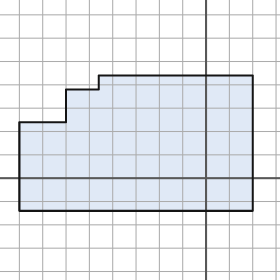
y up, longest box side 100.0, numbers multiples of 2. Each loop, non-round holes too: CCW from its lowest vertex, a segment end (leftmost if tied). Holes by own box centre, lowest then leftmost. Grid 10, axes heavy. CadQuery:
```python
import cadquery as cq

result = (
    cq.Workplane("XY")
    .moveTo(-80.0, -14.0)
    .lineTo(20.0, -14.0)
    .lineTo(20.0, 44.0)
    .lineTo(-46.0, 44.0)
    .lineTo(-46.0, 38.0)
    .lineTo(-60.0, 38.0)
    .lineTo(-60.0, 24.0)
    .lineTo(-80.0, 24.0)
    .close()
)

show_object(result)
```